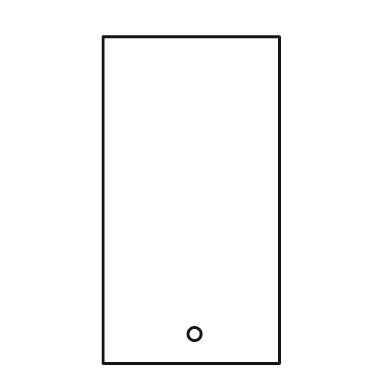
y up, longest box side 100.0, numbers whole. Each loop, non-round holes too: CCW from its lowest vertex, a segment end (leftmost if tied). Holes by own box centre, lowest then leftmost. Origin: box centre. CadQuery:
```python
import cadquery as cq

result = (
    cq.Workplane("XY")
    .moveTo(-27.0, -50.0)
    .lineTo(27.0, -50.0)
    .lineTo(27.0, 50.0)
    .lineTo(-27.0, 50.0)
    .close()
    .moveTo(1.0, -41.0)
    .circle(2.0)
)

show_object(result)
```